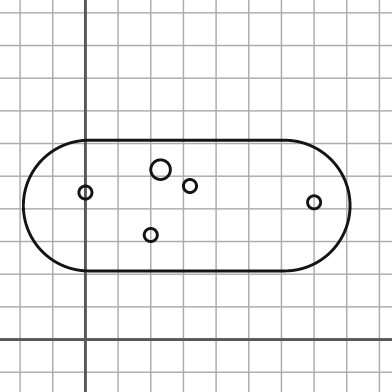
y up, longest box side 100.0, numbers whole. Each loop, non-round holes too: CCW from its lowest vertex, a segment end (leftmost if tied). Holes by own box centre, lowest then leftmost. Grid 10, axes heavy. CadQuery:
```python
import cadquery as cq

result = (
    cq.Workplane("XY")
    .moveTo(1.0, 21.0)
    .lineTo(61.0, 21.0)
    .threePointArc((81.0, 41.0), (61.0, 61.0))
    .lineTo(1.0, 61.0)
    .threePointArc((-19.0, 41.0), (1.0, 21.0))
    .close()
    .moveTo(20.0, 32.0)
    .circle(2.0)
    .moveTo(70.0, 42.0)
    .circle(2.0)
    .moveTo(0.0, 45.0)
    .circle(2.0)
    .moveTo(32.0, 47.0)
    .circle(2.0)
    .moveTo(23.0, 52.0)
    .circle(3.0)
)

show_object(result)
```